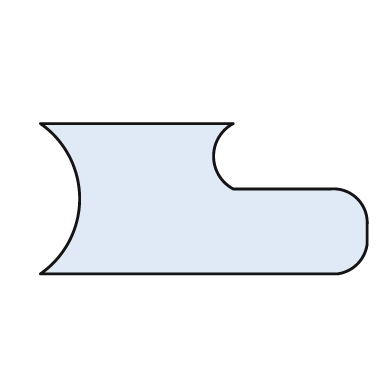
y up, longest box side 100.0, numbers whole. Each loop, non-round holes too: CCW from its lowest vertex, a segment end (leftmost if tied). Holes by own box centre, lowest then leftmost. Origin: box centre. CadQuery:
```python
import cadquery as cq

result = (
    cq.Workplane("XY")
    .moveTo(-50.0, -23.0)
    .lineTo(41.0, -23.0)
    .threePointArc((47.0, -20.0), (50.0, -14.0))
    .lineTo(50.0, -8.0)
    .threePointArc((47.0, 0.0), (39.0, 3.0))
    .lineTo(9.0, 3.0)
    .threePointArc((3.0, 13.0), (9.0, 23.0))
    .lineTo(-50.0, 23.0)
    .threePointArc((-38.0, 0.0), (-50.0, -23.0))
    .close()
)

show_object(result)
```